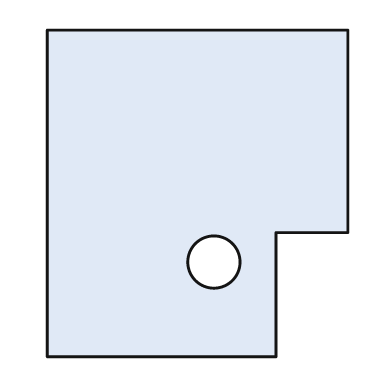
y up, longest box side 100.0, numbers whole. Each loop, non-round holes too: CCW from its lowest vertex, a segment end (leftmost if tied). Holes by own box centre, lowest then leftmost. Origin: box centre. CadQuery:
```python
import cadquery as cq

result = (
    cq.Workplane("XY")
    .moveTo(-46.0, -50.0)
    .lineTo(24.0, -50.0)
    .lineTo(24.0, -12.0)
    .lineTo(46.0, -12.0)
    .lineTo(46.0, 50.0)
    .lineTo(-46.0, 50.0)
    .close()
    .moveTo(5.0, -21.0)
    .circle(8.0)
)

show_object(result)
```